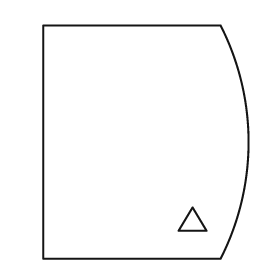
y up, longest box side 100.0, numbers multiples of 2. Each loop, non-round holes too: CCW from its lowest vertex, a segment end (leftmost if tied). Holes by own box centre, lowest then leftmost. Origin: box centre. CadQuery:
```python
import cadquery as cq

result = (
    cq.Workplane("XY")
    .moveTo(-44.0, -50.0)
    .lineTo(32.0, -50.0)
    .threePointArc((44.0, 0.0), (32.0, 50.0))
    .lineTo(-44.0, 50.0)
    .close()
    .moveTo(14.0, -38.0)
    .lineTo(26.0, -38.0)
    .lineTo(20.0, -28.0)
    .close()
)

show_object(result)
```